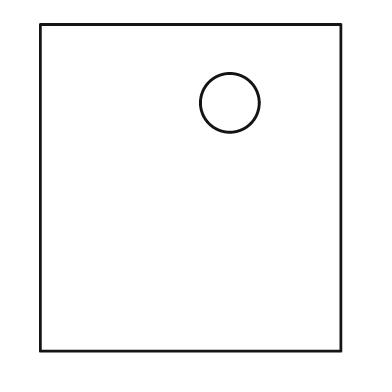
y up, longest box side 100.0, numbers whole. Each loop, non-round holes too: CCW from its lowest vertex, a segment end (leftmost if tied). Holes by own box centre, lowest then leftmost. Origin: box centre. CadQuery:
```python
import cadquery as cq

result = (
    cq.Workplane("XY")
    .moveTo(-46.0, -50.0)
    .lineTo(46.0, -50.0)
    .lineTo(46.0, 50.0)
    .lineTo(-46.0, 50.0)
    .close()
    .moveTo(12.0, 26.0)
    .circle(9.0)
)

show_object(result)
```